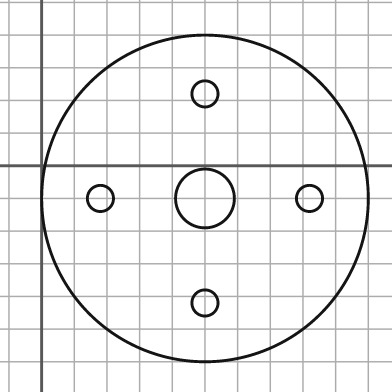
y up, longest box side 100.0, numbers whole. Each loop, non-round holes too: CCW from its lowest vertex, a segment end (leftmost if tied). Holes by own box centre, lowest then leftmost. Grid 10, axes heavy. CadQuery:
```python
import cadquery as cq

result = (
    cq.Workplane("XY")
    .moveTo(50.0, -10.0)
    .circle(50.0)
    .moveTo(50.0, -42.0)
    .circle(4.0)
    .moveTo(18.0, -10.0)
    .circle(4.0)
    .moveTo(50.0, -10.0)
    .circle(9.0)
    .moveTo(82.0, -10.0)
    .circle(4.0)
    .moveTo(50.0, 22.0)
    .circle(4.0)
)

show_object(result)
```